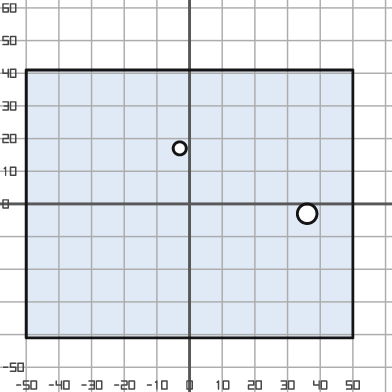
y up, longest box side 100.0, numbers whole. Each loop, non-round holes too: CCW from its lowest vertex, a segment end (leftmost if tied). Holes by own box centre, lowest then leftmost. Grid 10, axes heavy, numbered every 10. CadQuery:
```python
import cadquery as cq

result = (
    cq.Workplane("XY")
    .moveTo(-50.0, -41.0)
    .lineTo(50.0, -41.0)
    .lineTo(50.0, 41.0)
    .lineTo(-50.0, 41.0)
    .close()
    .moveTo(36.0, -3.0)
    .circle(3.0)
    .moveTo(-3.0, 17.0)
    .circle(2.0)
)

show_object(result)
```